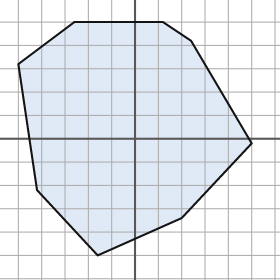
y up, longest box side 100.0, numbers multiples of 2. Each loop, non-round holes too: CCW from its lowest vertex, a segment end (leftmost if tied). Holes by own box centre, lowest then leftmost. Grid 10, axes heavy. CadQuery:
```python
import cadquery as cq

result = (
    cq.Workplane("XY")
    .moveTo(-16.0, -50.0)
    .lineTo(20.0, -34.0)
    .lineTo(50.0, -2.0)
    .lineTo(24.0, 42.0)
    .lineTo(12.0, 50.0)
    .lineTo(-26.0, 50.0)
    .lineTo(-50.0, 32.0)
    .lineTo(-42.0, -22.0)
    .close()
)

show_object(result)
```